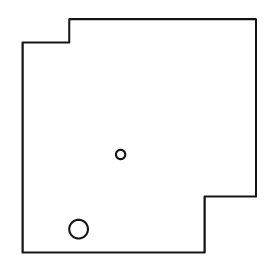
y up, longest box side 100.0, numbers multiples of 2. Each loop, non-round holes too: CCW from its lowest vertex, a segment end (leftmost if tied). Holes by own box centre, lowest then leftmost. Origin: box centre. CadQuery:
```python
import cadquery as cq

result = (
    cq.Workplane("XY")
    .moveTo(-50.0, -50.0)
    .lineTo(28.0, -50.0)
    .lineTo(28.0, -26.0)
    .lineTo(50.0, -26.0)
    .lineTo(50.0, 50.0)
    .lineTo(-30.0, 50.0)
    .lineTo(-30.0, 40.0)
    .lineTo(-50.0, 40.0)
    .close()
    .moveTo(-26.0, -40.0)
    .circle(4.0)
    .moveTo(-8.0, -8.0)
    .circle(2.0)
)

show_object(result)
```